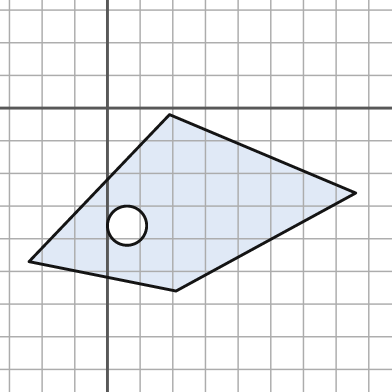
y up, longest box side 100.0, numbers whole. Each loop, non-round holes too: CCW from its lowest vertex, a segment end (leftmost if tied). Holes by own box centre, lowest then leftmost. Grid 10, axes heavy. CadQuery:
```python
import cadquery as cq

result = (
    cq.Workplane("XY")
    .moveTo(21.0, -56.0)
    .lineTo(76.0, -26.0)
    .lineTo(19.0, -2.0)
    .lineTo(-24.0, -47.0)
    .close()
    .moveTo(6.0, -36.0)
    .circle(6.0)
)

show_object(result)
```